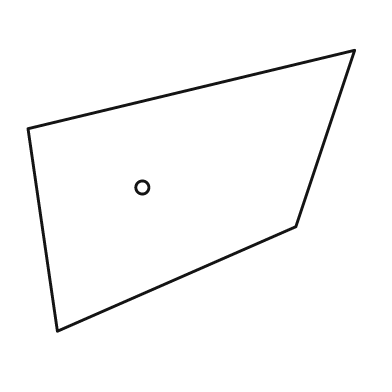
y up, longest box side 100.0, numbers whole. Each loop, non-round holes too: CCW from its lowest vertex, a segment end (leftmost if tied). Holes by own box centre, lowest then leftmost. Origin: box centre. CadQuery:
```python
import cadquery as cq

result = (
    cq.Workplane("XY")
    .moveTo(-41.0, -43.0)
    .lineTo(32.0, -11.0)
    .lineTo(50.0, 43.0)
    .lineTo(-50.0, 19.0)
    .close()
    .moveTo(-15.0, 1.0)
    .circle(2.0)
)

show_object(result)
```